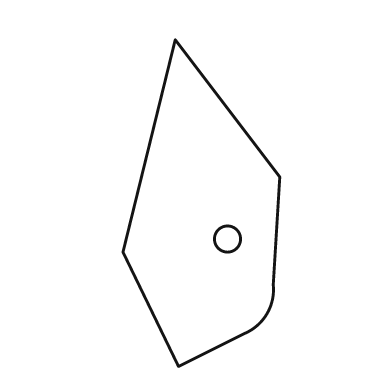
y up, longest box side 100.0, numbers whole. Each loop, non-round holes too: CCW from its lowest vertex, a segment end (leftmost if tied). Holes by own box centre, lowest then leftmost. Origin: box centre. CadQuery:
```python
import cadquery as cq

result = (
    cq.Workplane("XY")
    .moveTo(-7.0, -50.0)
    .lineTo(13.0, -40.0)
    .threePointArc((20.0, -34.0), (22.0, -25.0))
    .lineTo(24.0, 8.0)
    .lineTo(-8.0, 50.0)
    .lineTo(-24.0, -15.0)
    .close()
    .moveTo(8.0, -11.0)
    .circle(4.0)
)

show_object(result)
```